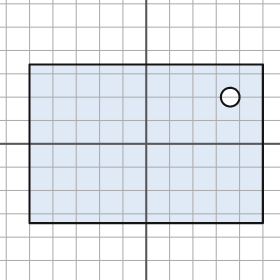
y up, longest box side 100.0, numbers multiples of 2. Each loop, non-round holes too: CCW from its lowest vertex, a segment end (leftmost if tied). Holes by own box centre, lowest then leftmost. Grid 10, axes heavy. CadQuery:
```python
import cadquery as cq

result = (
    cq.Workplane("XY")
    .moveTo(-50.0, -34.0)
    .lineTo(50.0, -34.0)
    .lineTo(50.0, 34.0)
    .lineTo(-50.0, 34.0)
    .close()
    .moveTo(36.0, 20.0)
    .circle(4.0)
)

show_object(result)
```